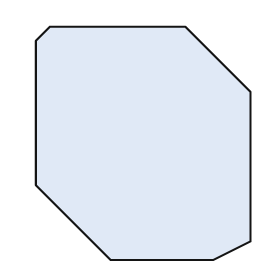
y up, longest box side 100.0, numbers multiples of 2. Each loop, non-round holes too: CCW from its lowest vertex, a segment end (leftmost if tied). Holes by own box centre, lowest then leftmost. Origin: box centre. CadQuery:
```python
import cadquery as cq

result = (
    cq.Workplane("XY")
    .moveTo(-14.0, -50.0)
    .lineTo(30.0, -50.0)
    .lineTo(46.0, -42.0)
    .lineTo(46.0, 22.0)
    .lineTo(18.0, 50.0)
    .lineTo(-40.0, 50.0)
    .lineTo(-46.0, 44.0)
    .lineTo(-46.0, -18.0)
    .close()
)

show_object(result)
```